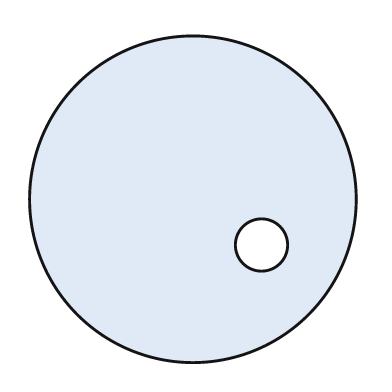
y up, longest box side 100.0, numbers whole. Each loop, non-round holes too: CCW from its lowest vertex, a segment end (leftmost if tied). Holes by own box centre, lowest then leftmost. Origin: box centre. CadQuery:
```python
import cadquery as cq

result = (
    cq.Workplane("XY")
    .moveTo(0.0, 0.0)
    .circle(50.0)
    .moveTo(21.0, -14.0)
    .circle(8.0)
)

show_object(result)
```